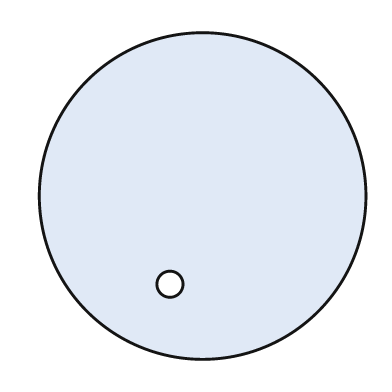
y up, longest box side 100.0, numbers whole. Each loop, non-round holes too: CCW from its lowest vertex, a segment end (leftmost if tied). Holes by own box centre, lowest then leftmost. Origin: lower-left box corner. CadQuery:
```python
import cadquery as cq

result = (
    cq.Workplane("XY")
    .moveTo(50.0, 50.0)
    .circle(50.0)
    .moveTo(40.0, 23.0)
    .circle(4.0)
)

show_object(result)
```